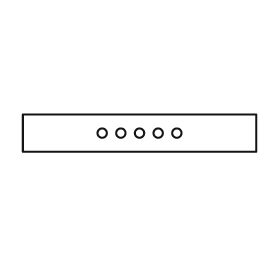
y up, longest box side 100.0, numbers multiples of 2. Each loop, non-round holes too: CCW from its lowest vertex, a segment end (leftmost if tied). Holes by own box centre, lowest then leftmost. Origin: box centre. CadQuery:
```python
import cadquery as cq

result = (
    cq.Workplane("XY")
    .moveTo(-50.0, -8.0)
    .lineTo(50.0, -8.0)
    .lineTo(50.0, 8.0)
    .lineTo(-50.0, 8.0)
    .close()
    .moveTo(-16.0, 0.0)
    .circle(2.0)
    .moveTo(-8.0, 0.0)
    .circle(2.0)
    .moveTo(0.0, 0.0)
    .circle(2.0)
    .moveTo(8.0, 0.0)
    .circle(2.0)
    .moveTo(16.0, 0.0)
    .circle(2.0)
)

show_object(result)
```